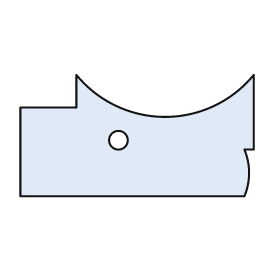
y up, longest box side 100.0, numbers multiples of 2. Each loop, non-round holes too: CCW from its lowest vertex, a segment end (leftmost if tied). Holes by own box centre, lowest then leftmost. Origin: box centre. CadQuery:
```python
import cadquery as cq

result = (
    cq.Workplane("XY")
    .moveTo(-50.0, -26.0)
    .lineTo(46.0, -26.0)
    .threePointArc((48.0, -16.0), (46.0, -6.0))
    .lineTo(50.0, -6.0)
    .lineTo(50.0, 26.0)
    .threePointArc((12.0, 8.0), (-26.0, 26.0))
    .lineTo(-26.0, 12.0)
    .lineTo(-50.0, 12.0)
    .close()
    .moveTo(-8.0, -2.0)
    .circle(4.0)
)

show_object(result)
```